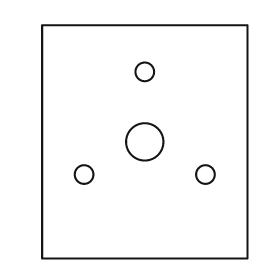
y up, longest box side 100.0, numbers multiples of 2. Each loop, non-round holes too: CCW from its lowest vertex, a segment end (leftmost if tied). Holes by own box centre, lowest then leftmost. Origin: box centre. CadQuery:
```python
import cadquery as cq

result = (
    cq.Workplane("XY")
    .moveTo(-44.0, -50.0)
    .lineTo(44.0, -50.0)
    .lineTo(44.0, 50.0)
    .lineTo(-44.0, 50.0)
    .close()
    .moveTo(-26.0, -14.0)
    .circle(4.0)
    .moveTo(26.0, -14.0)
    .circle(4.0)
    .moveTo(0.0, 0.0)
    .circle(8.0)
    .moveTo(0.0, 30.0)
    .circle(4.0)
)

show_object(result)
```